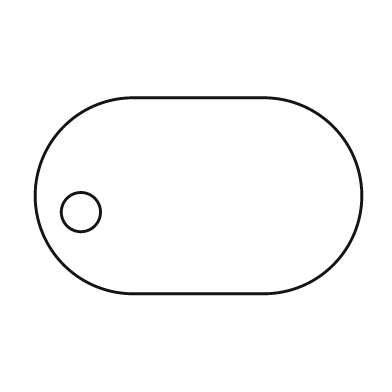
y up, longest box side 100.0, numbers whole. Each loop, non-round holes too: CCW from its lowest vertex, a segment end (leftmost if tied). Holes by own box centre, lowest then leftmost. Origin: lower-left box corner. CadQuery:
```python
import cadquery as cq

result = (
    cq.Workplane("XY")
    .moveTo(30.0, 0.0)
    .lineTo(70.0, 0.0)
    .threePointArc((100.0, 30.0), (70.0, 60.0))
    .lineTo(30.0, 60.0)
    .threePointArc((0.0, 30.0), (30.0, 0.0))
    .close()
    .moveTo(14.0, 25.0)
    .circle(6.0)
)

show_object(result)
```